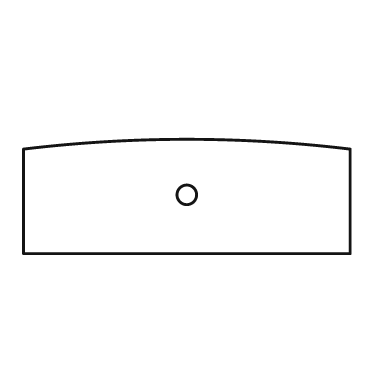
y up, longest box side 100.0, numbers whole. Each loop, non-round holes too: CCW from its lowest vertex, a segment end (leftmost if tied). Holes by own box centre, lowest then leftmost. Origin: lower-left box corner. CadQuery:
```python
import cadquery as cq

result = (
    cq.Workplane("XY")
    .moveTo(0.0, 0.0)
    .lineTo(100.0, 0.0)
    .lineTo(100.0, 32.0)
    .threePointArc((50.0, 35.0), (0.0, 32.0))
    .close()
    .moveTo(50.0, 18.0)
    .circle(3.0)
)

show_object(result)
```